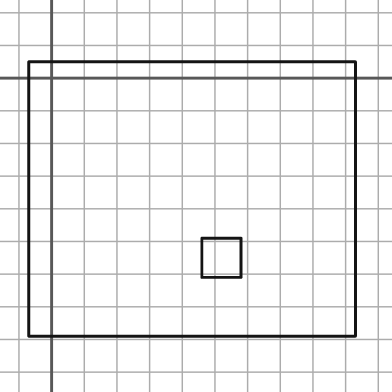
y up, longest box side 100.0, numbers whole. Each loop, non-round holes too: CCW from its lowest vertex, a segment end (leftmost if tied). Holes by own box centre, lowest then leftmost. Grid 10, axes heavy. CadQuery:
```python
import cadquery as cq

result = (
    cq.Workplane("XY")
    .moveTo(-7.0, -79.0)
    .lineTo(93.0, -79.0)
    .lineTo(93.0, 5.0)
    .lineTo(-7.0, 5.0)
    .close()
    .moveTo(46.0, -61.0)
    .lineTo(58.0, -61.0)
    .lineTo(58.0, -49.0)
    .lineTo(46.0, -49.0)
    .close()
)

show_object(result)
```